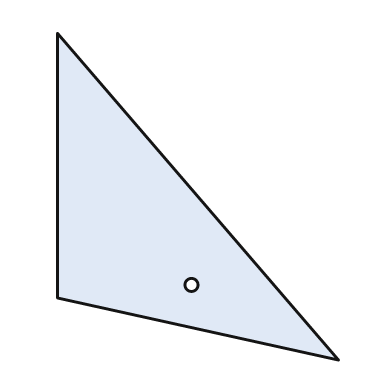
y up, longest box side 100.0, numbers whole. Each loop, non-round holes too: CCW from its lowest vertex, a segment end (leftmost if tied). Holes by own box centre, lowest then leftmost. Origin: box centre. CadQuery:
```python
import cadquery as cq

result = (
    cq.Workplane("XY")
    .moveTo(43.0, -50.0)
    .lineTo(-43.0, 50.0)
    .lineTo(-43.0, -31.0)
    .close()
    .moveTo(-2.0, -27.0)
    .circle(2.0)
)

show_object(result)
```